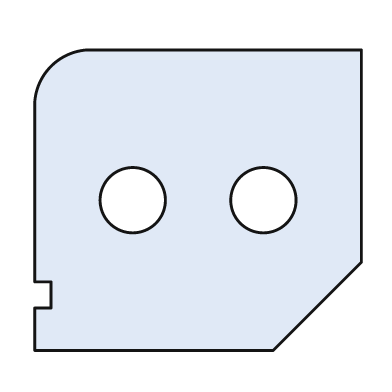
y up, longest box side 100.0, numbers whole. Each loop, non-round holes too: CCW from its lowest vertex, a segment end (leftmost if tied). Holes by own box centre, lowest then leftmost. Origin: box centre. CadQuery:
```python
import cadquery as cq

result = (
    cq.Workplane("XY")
    .moveTo(-50.0, -46.0)
    .lineTo(23.0, -46.0)
    .lineTo(50.0, -19.0)
    .lineTo(50.0, 46.0)
    .lineTo(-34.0, 46.0)
    .threePointArc((-45.0, 41.0), (-50.0, 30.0))
    .lineTo(-50.0, -25.0)
    .lineTo(-45.0, -25.0)
    .lineTo(-45.0, -33.0)
    .lineTo(-50.0, -33.0)
    .close()
    .moveTo(-20.0, 0.0)
    .circle(10.0)
    .moveTo(20.0, 0.0)
    .circle(10.0)
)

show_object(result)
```